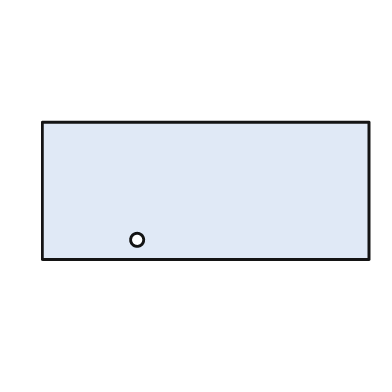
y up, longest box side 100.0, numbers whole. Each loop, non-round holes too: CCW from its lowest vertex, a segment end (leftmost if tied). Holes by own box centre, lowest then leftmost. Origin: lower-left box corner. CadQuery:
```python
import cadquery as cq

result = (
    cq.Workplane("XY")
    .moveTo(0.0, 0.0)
    .lineTo(100.0, 0.0)
    .lineTo(100.0, 42.0)
    .lineTo(0.0, 42.0)
    .close()
    .moveTo(29.0, 6.0)
    .circle(2.0)
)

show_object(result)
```